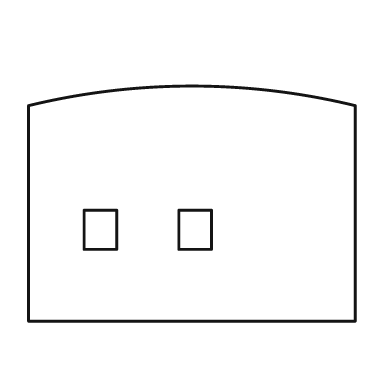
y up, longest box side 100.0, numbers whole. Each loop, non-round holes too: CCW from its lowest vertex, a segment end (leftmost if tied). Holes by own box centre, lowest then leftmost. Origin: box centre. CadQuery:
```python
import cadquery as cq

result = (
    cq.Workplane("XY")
    .moveTo(-50.0, -36.0)
    .lineTo(50.0, -36.0)
    .lineTo(50.0, 30.0)
    .threePointArc((0.0, 36.0), (-50.0, 30.0))
    .close()
    .moveTo(-33.0, -14.0)
    .lineTo(-23.0, -14.0)
    .lineTo(-23.0, -2.0)
    .lineTo(-33.0, -2.0)
    .close()
    .moveTo(-4.0, -14.0)
    .lineTo(6.0, -14.0)
    .lineTo(6.0, -2.0)
    .lineTo(-4.0, -2.0)
    .close()
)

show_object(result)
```